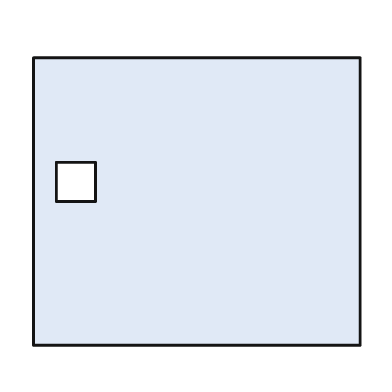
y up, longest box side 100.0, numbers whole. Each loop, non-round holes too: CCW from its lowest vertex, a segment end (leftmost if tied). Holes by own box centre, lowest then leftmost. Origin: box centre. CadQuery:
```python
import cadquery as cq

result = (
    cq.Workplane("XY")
    .moveTo(-50.0, -44.0)
    .lineTo(50.0, -44.0)
    .lineTo(50.0, 44.0)
    .lineTo(-50.0, 44.0)
    .close()
    .moveTo(-43.0, 0.0)
    .lineTo(-31.0, 0.0)
    .lineTo(-31.0, 12.0)
    .lineTo(-43.0, 12.0)
    .close()
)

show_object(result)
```